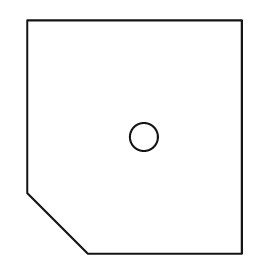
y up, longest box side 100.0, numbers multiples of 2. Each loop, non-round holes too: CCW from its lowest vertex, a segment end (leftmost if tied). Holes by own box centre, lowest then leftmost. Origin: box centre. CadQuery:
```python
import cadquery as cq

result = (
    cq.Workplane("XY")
    .moveTo(-20.0, -50.0)
    .lineTo(46.0, -50.0)
    .lineTo(46.0, 50.0)
    .lineTo(-46.0, 50.0)
    .lineTo(-46.0, -24.0)
    .close()
    .moveTo(4.0, 0.0)
    .circle(6.0)
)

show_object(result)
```